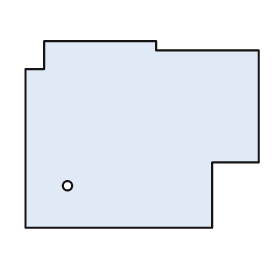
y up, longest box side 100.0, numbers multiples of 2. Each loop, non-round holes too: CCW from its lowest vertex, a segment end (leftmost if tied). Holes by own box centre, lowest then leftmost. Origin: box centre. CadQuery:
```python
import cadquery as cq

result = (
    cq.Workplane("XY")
    .moveTo(-50.0, -40.0)
    .lineTo(30.0, -40.0)
    .lineTo(30.0, -12.0)
    .lineTo(50.0, -12.0)
    .lineTo(50.0, 36.0)
    .lineTo(6.0, 36.0)
    .lineTo(6.0, 40.0)
    .lineTo(-42.0, 40.0)
    .lineTo(-42.0, 28.0)
    .lineTo(-50.0, 28.0)
    .close()
    .moveTo(-32.0, -22.0)
    .circle(2.0)
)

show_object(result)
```